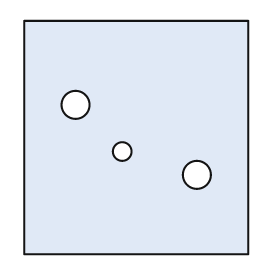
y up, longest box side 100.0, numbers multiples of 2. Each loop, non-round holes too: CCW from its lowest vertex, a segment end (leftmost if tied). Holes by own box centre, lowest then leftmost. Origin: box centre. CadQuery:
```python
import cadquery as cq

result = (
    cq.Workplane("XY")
    .moveTo(-48.0, -50.0)
    .lineTo(48.0, -50.0)
    .lineTo(48.0, 50.0)
    .lineTo(-48.0, 50.0)
    .close()
    .moveTo(26.0, -16.0)
    .circle(6.0)
    .moveTo(-6.0, -6.0)
    .circle(4.0)
    .moveTo(-26.0, 14.0)
    .circle(6.0)
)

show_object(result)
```